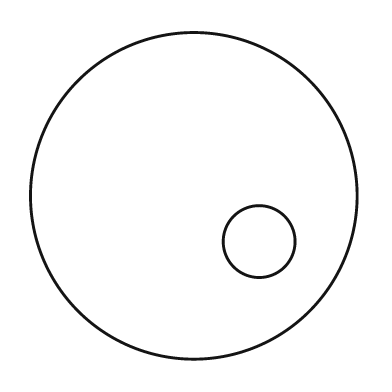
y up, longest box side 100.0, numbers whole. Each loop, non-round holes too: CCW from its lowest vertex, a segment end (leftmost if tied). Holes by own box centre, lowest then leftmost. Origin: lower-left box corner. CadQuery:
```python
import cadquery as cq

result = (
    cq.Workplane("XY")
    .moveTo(50.0, 50.0)
    .circle(50.0)
    .moveTo(70.0, 36.0)
    .circle(11.0)
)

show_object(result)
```